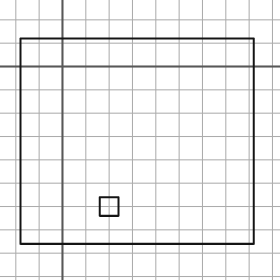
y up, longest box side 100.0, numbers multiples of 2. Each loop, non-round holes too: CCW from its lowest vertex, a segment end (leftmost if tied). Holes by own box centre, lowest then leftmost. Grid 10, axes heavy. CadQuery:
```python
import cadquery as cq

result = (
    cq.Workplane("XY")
    .moveTo(-18.0, -76.0)
    .lineTo(82.0, -76.0)
    .lineTo(82.0, 12.0)
    .lineTo(-18.0, 12.0)
    .close()
    .moveTo(16.0, -64.0)
    .lineTo(24.0, -64.0)
    .lineTo(24.0, -56.0)
    .lineTo(16.0, -56.0)
    .close()
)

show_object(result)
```